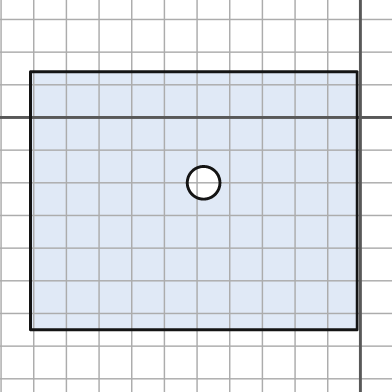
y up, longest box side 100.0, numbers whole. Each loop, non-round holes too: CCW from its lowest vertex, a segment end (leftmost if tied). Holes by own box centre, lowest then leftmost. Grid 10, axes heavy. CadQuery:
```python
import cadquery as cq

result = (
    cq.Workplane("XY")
    .moveTo(-101.0, -65.0)
    .lineTo(-1.0, -65.0)
    .lineTo(-1.0, 14.0)
    .lineTo(-101.0, 14.0)
    .close()
    .moveTo(-48.0, -20.0)
    .circle(5.0)
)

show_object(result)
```